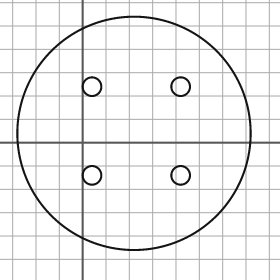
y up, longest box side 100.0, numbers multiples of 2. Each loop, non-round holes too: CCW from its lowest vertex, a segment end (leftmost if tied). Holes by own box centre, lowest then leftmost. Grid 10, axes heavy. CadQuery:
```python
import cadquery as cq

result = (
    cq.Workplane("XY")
    .moveTo(22.0, 4.0)
    .circle(50.0)
    .moveTo(4.0, -14.0)
    .circle(4.0)
    .moveTo(42.0, -14.0)
    .circle(4.0)
    .moveTo(4.0, 24.0)
    .circle(4.0)
    .moveTo(42.0, 24.0)
    .circle(4.0)
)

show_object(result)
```